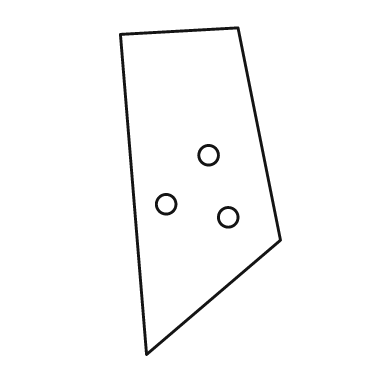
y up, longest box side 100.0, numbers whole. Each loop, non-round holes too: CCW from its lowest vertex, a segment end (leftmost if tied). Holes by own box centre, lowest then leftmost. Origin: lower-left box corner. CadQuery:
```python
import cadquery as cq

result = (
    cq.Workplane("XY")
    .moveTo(8.0, 0.0)
    .lineTo(49.0, 35.0)
    .lineTo(36.0, 100.0)
    .lineTo(0.0, 98.0)
    .close()
    .moveTo(33.0, 42.0)
    .circle(3.0)
    .moveTo(14.0, 46.0)
    .circle(3.0)
    .moveTo(27.0, 61.0)
    .circle(3.0)
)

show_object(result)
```